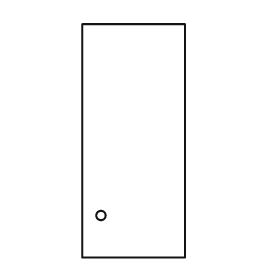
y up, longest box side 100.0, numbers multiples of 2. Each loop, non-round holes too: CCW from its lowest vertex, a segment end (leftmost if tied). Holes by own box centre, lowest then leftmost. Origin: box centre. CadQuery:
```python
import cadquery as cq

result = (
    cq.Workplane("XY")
    .moveTo(-22.0, -50.0)
    .lineTo(22.0, -50.0)
    .lineTo(22.0, 50.0)
    .lineTo(-22.0, 50.0)
    .close()
    .moveTo(-14.0, -32.0)
    .circle(2.0)
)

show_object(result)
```